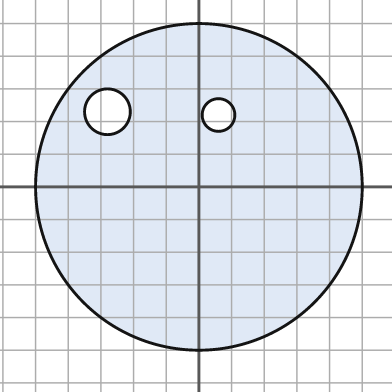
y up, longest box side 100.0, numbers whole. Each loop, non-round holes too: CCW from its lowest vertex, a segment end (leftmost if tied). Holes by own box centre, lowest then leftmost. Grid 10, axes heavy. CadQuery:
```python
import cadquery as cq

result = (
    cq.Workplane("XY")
    .moveTo(0.0, 0.0)
    .circle(50.0)
    .moveTo(6.0, 22.0)
    .circle(5.0)
    .moveTo(-28.0, 23.0)
    .circle(7.0)
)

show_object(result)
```